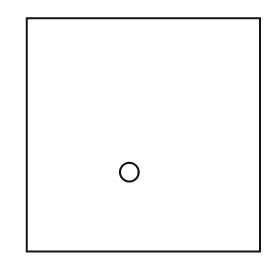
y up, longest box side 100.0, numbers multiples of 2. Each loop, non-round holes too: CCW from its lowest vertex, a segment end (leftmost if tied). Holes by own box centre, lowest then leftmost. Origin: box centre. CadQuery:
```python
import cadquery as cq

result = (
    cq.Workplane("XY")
    .moveTo(-50.0, -50.0)
    .lineTo(50.0, -50.0)
    .lineTo(50.0, 50.0)
    .lineTo(-50.0, 50.0)
    .close()
    .moveTo(-6.0, -16.0)
    .circle(4.0)
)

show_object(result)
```